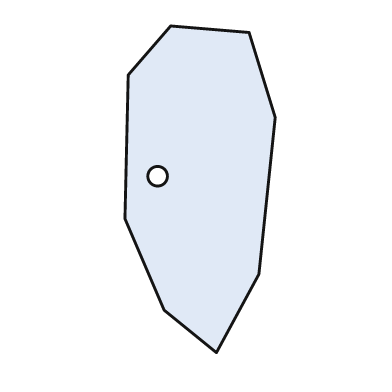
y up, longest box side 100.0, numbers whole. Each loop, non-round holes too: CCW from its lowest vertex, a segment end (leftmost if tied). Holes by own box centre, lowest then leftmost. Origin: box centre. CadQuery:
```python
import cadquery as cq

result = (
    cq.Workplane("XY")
    .moveTo(5.0, -50.0)
    .lineTo(18.0, -26.0)
    .lineTo(23.0, 22.0)
    .lineTo(15.0, 48.0)
    .lineTo(-9.0, 50.0)
    .lineTo(-22.0, 35.0)
    .lineTo(-23.0, -9.0)
    .lineTo(-11.0, -37.0)
    .close()
    .moveTo(-13.0, 4.0)
    .circle(3.0)
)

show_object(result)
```